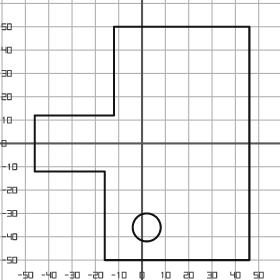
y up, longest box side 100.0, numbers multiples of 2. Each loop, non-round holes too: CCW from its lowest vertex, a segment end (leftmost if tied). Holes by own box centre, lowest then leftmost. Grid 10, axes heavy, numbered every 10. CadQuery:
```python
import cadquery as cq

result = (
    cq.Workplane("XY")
    .moveTo(-16.0, -50.0)
    .lineTo(46.0, -50.0)
    .lineTo(46.0, 50.0)
    .lineTo(-12.0, 50.0)
    .lineTo(-12.0, 12.0)
    .lineTo(-46.0, 12.0)
    .lineTo(-46.0, -12.0)
    .lineTo(-16.0, -12.0)
    .close()
    .moveTo(2.0, -36.0)
    .circle(6.0)
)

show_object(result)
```